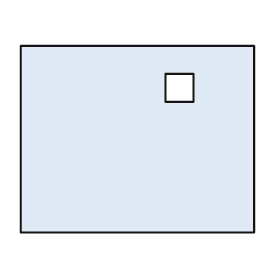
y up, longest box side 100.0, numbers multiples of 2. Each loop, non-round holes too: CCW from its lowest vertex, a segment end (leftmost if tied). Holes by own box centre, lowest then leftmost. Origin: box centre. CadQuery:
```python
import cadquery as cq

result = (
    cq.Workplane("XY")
    .moveTo(-50.0, -40.0)
    .lineTo(50.0, -40.0)
    .lineTo(50.0, 40.0)
    .lineTo(-50.0, 40.0)
    .close()
    .moveTo(12.0, 16.0)
    .lineTo(24.0, 16.0)
    .lineTo(24.0, 28.0)
    .lineTo(12.0, 28.0)
    .close()
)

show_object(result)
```